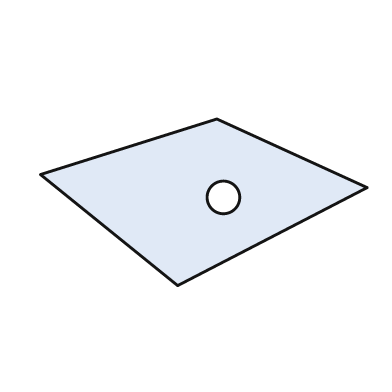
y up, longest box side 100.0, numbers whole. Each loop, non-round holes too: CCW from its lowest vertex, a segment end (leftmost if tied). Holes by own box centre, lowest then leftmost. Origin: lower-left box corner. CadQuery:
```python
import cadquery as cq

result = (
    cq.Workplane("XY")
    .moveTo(42.0, 0.0)
    .lineTo(100.0, 30.0)
    .lineTo(54.0, 51.0)
    .lineTo(0.0, 34.0)
    .close()
    .moveTo(56.0, 27.0)
    .circle(5.0)
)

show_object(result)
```